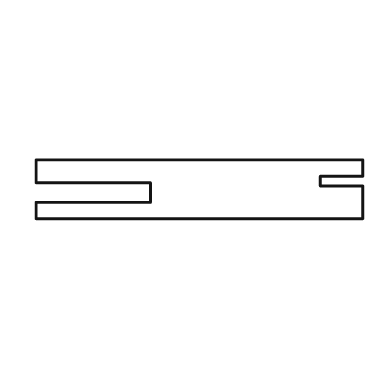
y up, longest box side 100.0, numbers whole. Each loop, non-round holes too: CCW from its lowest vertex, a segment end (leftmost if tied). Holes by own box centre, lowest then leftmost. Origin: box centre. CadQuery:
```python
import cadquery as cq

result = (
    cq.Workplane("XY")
    .moveTo(-50.0, -9.0)
    .lineTo(50.0, -9.0)
    .lineTo(50.0, 1.0)
    .lineTo(37.0, 1.0)
    .lineTo(37.0, 4.0)
    .lineTo(50.0, 4.0)
    .lineTo(50.0, 9.0)
    .lineTo(-50.0, 9.0)
    .lineTo(-50.0, 2.0)
    .lineTo(-15.0, 2.0)
    .lineTo(-15.0, -4.0)
    .lineTo(-50.0, -4.0)
    .close()
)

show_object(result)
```